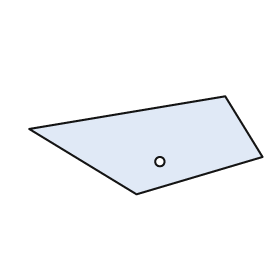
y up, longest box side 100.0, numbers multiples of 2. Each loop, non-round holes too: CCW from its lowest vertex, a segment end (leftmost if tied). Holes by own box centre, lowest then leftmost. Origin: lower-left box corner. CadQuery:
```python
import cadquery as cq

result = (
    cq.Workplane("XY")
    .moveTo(46.0, 0.0)
    .lineTo(100.0, 16.0)
    .lineTo(84.0, 42.0)
    .lineTo(0.0, 28.0)
    .close()
    .moveTo(56.0, 14.0)
    .circle(2.0)
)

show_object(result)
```